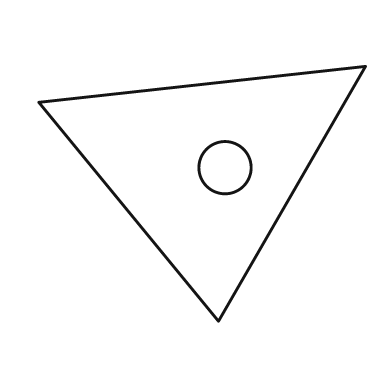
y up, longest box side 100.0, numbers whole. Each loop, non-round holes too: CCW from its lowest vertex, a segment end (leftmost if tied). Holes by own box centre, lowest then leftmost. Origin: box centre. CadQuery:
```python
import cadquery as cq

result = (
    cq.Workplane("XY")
    .moveTo(5.0, -39.0)
    .lineTo(50.0, 39.0)
    .lineTo(-50.0, 28.0)
    .close()
    .moveTo(7.0, 8.0)
    .circle(8.0)
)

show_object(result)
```